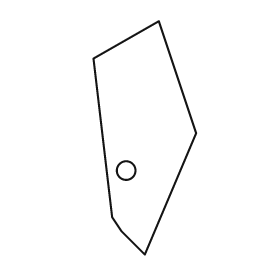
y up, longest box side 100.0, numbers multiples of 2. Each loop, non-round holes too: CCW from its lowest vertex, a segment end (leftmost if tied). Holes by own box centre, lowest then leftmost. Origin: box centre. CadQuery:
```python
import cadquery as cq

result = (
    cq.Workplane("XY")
    .moveTo(0.0, -50.0)
    .lineTo(22.0, 2.0)
    .lineTo(6.0, 50.0)
    .lineTo(-22.0, 34.0)
    .lineTo(-14.0, -34.0)
    .lineTo(-10.0, -40.0)
    .close()
    .moveTo(-8.0, -14.0)
    .circle(4.0)
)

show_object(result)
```